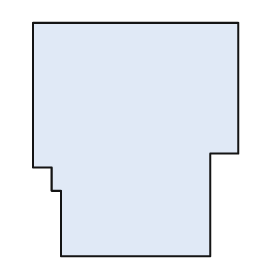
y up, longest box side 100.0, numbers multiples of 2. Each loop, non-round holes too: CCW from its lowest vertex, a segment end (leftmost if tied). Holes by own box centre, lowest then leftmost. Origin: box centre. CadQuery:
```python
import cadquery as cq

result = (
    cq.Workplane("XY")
    .moveTo(-32.0, -50.0)
    .lineTo(32.0, -50.0)
    .lineTo(32.0, -6.0)
    .lineTo(44.0, -6.0)
    .lineTo(44.0, 50.0)
    .lineTo(-44.0, 50.0)
    .lineTo(-44.0, -12.0)
    .lineTo(-36.0, -12.0)
    .lineTo(-36.0, -22.0)
    .lineTo(-32.0, -22.0)
    .close()
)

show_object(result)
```